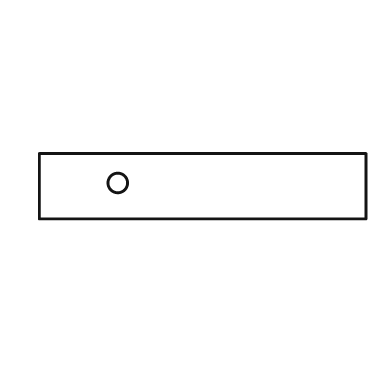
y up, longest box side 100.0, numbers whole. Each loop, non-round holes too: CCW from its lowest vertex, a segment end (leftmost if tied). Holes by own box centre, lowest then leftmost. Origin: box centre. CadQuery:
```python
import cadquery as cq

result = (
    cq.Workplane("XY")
    .moveTo(-50.0, -10.0)
    .lineTo(50.0, -10.0)
    .lineTo(50.0, 10.0)
    .lineTo(-50.0, 10.0)
    .close()
    .moveTo(-26.0, 1.0)
    .circle(3.0)
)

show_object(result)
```